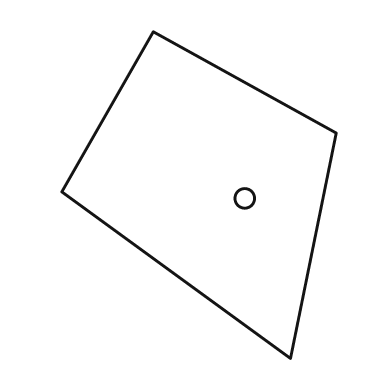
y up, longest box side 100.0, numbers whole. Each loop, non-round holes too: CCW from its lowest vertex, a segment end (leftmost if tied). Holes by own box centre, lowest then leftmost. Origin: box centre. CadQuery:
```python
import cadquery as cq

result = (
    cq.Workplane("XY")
    .moveTo(28.0, -50.0)
    .lineTo(42.0, 19.0)
    .lineTo(-14.0, 50.0)
    .lineTo(-42.0, 1.0)
    .close()
    .moveTo(14.0, -1.0)
    .circle(3.0)
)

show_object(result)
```